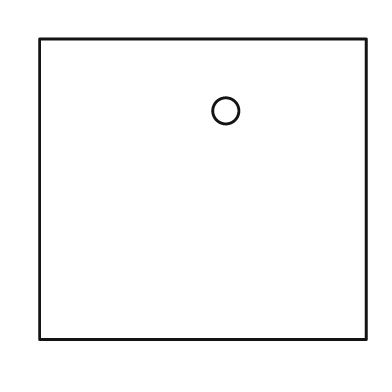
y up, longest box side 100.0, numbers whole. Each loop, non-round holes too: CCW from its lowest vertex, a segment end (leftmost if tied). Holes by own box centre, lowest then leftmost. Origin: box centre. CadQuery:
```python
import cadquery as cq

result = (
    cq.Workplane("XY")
    .moveTo(-50.0, -46.0)
    .lineTo(50.0, -46.0)
    .lineTo(50.0, 46.0)
    .lineTo(-50.0, 46.0)
    .close()
    .moveTo(7.0, 24.0)
    .circle(4.0)
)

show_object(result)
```